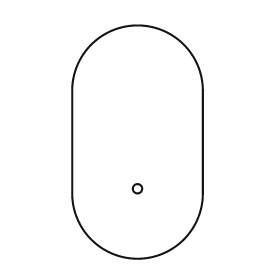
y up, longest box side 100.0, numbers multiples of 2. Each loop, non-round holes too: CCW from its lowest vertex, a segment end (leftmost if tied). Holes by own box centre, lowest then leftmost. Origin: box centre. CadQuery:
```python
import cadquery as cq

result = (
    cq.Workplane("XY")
    .moveTo(-28.0, -22.0)
    .threePointArc((0.0, -50.0), (28.0, -22.0))
    .lineTo(28.0, 22.0)
    .threePointArc((0.0, 50.0), (-28.0, 22.0))
    .close()
    .moveTo(0.0, -20.0)
    .circle(2.0)
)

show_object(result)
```